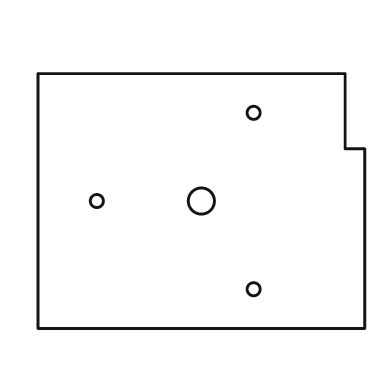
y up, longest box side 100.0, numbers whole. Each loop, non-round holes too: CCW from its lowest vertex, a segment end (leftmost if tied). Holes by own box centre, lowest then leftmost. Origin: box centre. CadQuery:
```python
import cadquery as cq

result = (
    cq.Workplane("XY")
    .moveTo(-50.0, -39.0)
    .lineTo(50.0, -39.0)
    .lineTo(50.0, 16.0)
    .lineTo(44.0, 16.0)
    .lineTo(44.0, 39.0)
    .lineTo(-50.0, 39.0)
    .close()
    .moveTo(16.0, -27.0)
    .circle(2.0)
    .moveTo(-32.0, 0.0)
    .circle(2.0)
    .moveTo(0.0, 0.0)
    .circle(4.0)
    .moveTo(16.0, 27.0)
    .circle(2.0)
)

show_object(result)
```